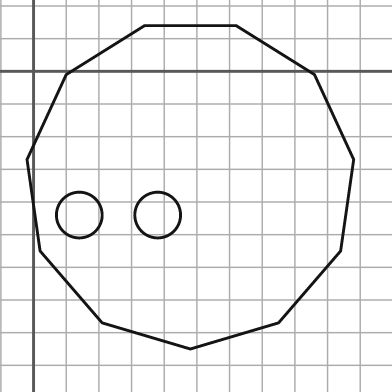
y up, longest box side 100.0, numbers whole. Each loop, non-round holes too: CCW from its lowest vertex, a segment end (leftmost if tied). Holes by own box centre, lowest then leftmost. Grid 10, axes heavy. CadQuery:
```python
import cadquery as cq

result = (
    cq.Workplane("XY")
    .moveTo(48.0, -85.0)
    .lineTo(75.0, -77.0)
    .lineTo(94.0, -55.0)
    .lineTo(98.0, -27.0)
    .lineTo(86.0, -1.0)
    .lineTo(62.0, 14.0)
    .lineTo(34.0, 14.0)
    .lineTo(10.0, -1.0)
    .lineTo(-2.0, -27.0)
    .lineTo(2.0, -55.0)
    .lineTo(21.0, -77.0)
    .close()
    .moveTo(14.0, -44.0)
    .circle(7.0)
    .moveTo(38.0, -44.0)
    .circle(7.0)
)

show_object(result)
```